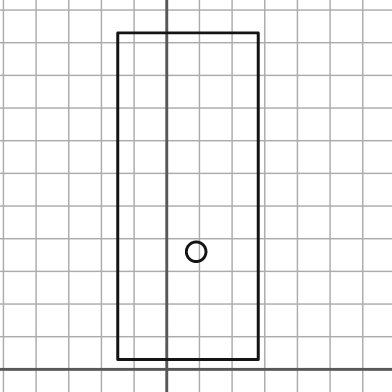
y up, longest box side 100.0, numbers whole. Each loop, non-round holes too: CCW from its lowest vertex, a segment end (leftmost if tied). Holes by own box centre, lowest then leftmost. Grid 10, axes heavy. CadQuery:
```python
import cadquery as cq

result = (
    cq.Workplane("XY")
    .moveTo(-15.0, 3.0)
    .lineTo(28.0, 3.0)
    .lineTo(28.0, 103.0)
    .lineTo(-15.0, 103.0)
    .close()
    .moveTo(9.0, 36.0)
    .circle(3.0)
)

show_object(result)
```